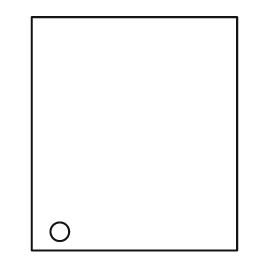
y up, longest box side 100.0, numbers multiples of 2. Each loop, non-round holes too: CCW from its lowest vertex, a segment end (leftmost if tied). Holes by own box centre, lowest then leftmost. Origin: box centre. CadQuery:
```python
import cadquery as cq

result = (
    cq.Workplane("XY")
    .moveTo(-44.0, -50.0)
    .lineTo(44.0, -50.0)
    .lineTo(44.0, 50.0)
    .lineTo(-44.0, 50.0)
    .close()
    .moveTo(-32.0, -42.0)
    .circle(4.0)
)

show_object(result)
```